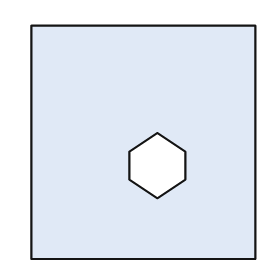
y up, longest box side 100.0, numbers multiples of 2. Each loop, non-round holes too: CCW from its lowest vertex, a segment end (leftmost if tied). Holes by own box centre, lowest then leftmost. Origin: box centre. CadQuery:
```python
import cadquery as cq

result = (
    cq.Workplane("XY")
    .moveTo(-48.0, -50.0)
    .lineTo(48.0, -50.0)
    .lineTo(48.0, 50.0)
    .lineTo(-48.0, 50.0)
    .close()
    .moveTo(6.0, -24.0)
    .lineTo(18.0, -16.0)
    .lineTo(18.0, -4.0)
    .lineTo(6.0, 4.0)
    .lineTo(-6.0, -4.0)
    .lineTo(-6.0, -16.0)
    .close()
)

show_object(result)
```